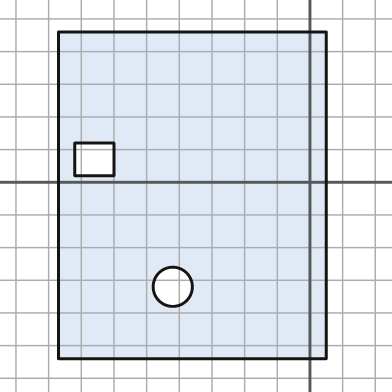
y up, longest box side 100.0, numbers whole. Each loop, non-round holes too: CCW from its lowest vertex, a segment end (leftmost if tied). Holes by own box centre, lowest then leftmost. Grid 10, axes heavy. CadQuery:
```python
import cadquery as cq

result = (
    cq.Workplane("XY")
    .moveTo(-77.0, -54.0)
    .lineTo(5.0, -54.0)
    .lineTo(5.0, 46.0)
    .lineTo(-77.0, 46.0)
    .close()
    .moveTo(-42.0, -32.0)
    .circle(6.0)
    .moveTo(-72.0, 2.0)
    .lineTo(-60.0, 2.0)
    .lineTo(-60.0, 12.0)
    .lineTo(-72.0, 12.0)
    .close()
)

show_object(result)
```